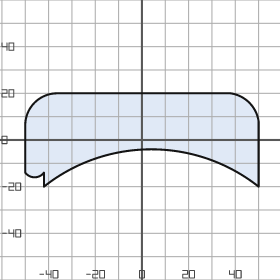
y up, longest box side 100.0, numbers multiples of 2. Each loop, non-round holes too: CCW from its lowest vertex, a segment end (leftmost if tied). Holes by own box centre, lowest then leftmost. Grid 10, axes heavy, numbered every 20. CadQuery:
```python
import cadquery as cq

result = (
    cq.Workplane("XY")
    .moveTo(-42.0, -20.0)
    .threePointArc((4.0, -4.0), (50.0, -20.0))
    .lineTo(50.0, 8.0)
    .threePointArc((46.0, 16.0), (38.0, 20.0))
    .lineTo(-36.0, 20.0)
    .threePointArc((-46.0, 16.0), (-50.0, 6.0))
    .lineTo(-50.0, -14.0)
    .threePointArc((-46.0, -16.0), (-42.0, -14.0))
    .close()
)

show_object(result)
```